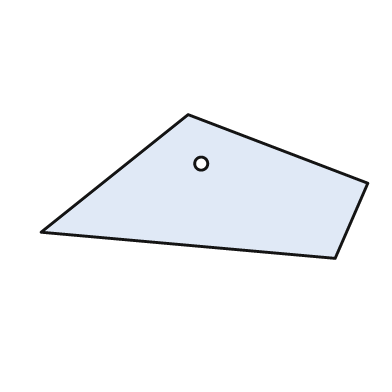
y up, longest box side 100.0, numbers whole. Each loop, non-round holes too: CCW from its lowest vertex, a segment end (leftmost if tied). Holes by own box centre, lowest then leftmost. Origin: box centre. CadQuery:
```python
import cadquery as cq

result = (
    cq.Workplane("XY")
    .moveTo(40.0, -22.0)
    .lineTo(50.0, 1.0)
    .lineTo(-5.0, 22.0)
    .lineTo(-50.0, -14.0)
    .close()
    .moveTo(-1.0, 7.0)
    .circle(2.0)
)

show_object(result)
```